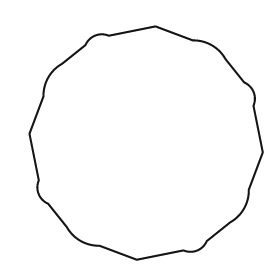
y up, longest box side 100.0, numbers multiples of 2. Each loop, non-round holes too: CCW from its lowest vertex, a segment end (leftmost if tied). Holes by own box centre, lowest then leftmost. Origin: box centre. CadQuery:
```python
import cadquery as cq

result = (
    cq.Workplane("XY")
    .moveTo(-4.0, -50.0)
    .lineTo(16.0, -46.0)
    .threePointArc((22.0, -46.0), (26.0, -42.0))
    .lineTo(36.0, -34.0)
    .threePointArc((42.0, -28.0), (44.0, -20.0))
    .lineTo(50.0, -4.0)
    .lineTo(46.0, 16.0)
    .threePointArc((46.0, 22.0), (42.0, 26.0))
    .lineTo(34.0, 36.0)
    .threePointArc((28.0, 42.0), (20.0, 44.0))
    .lineTo(4.0, 50.0)
    .lineTo(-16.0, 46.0)
    .threePointArc((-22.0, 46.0), (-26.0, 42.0))
    .lineTo(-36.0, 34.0)
    .threePointArc((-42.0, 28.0), (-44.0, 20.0))
    .lineTo(-50.0, 4.0)
    .lineTo(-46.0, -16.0)
    .threePointArc((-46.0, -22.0), (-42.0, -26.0))
    .lineTo(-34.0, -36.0)
    .threePointArc((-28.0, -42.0), (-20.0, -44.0))
    .close()
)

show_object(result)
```